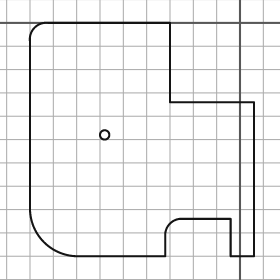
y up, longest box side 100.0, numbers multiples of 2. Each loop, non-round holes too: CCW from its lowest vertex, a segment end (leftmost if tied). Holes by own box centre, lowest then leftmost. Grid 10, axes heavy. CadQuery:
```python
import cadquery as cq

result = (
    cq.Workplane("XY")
    .moveTo(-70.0, -100.0)
    .lineTo(-32.0, -100.0)
    .lineTo(-32.0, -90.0)
    .threePointArc((-30.0, -86.0), (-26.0, -84.0))
    .lineTo(-4.0, -84.0)
    .lineTo(-4.0, -100.0)
    .lineTo(6.0, -100.0)
    .lineTo(6.0, -34.0)
    .lineTo(-30.0, -34.0)
    .lineTo(-30.0, 0.0)
    .lineTo(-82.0, 0.0)
    .threePointArc((-88.0, -2.0), (-90.0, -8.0))
    .lineTo(-90.0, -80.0)
    .threePointArc((-84.0, -94.0), (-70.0, -100.0))
    .close()
    .moveTo(-58.0, -48.0)
    .circle(2.0)
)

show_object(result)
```